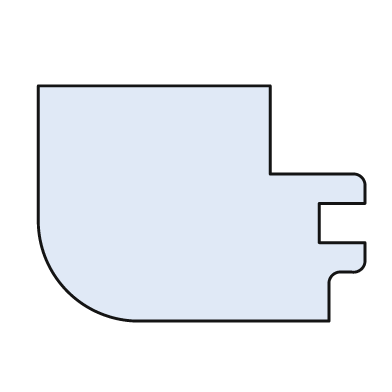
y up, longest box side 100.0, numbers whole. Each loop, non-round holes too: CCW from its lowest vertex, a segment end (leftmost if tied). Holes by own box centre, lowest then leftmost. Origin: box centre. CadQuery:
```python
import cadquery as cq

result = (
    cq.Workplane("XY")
    .moveTo(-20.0, -36.0)
    .lineTo(39.0, -36.0)
    .lineTo(39.0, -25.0)
    .threePointArc((40.0, -22.0), (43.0, -21.0))
    .lineTo(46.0, -21.0)
    .threePointArc((49.0, -20.0), (50.0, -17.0))
    .lineTo(50.0, -12.0)
    .lineTo(36.0, -12.0)
    .lineTo(36.0, 0.0)
    .lineTo(50.0, 0.0)
    .lineTo(50.0, 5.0)
    .threePointArc((49.0, 8.0), (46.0, 9.0))
    .lineTo(21.0, 9.0)
    .lineTo(21.0, 36.0)
    .lineTo(-50.0, 36.0)
    .lineTo(-50.0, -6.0)
    .threePointArc((-41.0, -27.0), (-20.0, -36.0))
    .close()
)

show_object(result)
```